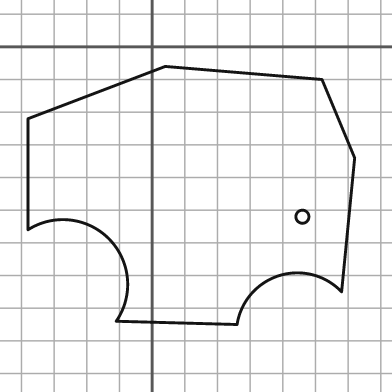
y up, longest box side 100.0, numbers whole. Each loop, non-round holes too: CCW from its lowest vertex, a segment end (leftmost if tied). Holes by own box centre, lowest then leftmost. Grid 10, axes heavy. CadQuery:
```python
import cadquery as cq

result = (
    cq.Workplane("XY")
    .moveTo(26.0, -85.0)
    .threePointArc((39.0, -70.0), (58.0, -75.0))
    .lineTo(62.0, -34.0)
    .lineTo(52.0, -10.0)
    .lineTo(4.0, -6.0)
    .lineTo(-38.0, -22.0)
    .lineTo(-38.0, -56.0)
    .threePointArc((-13.0, -59.0), (-11.0, -84.0))
    .close()
    .moveTo(46.0, -52.0)
    .circle(2.0)
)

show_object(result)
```